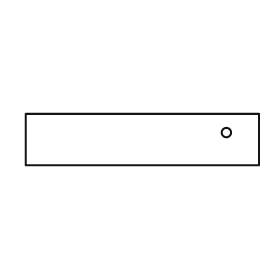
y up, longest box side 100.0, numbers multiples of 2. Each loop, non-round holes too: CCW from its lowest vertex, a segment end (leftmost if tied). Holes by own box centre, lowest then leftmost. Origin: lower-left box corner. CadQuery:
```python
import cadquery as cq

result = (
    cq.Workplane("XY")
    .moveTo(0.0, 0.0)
    .lineTo(100.0, 0.0)
    .lineTo(100.0, 22.0)
    .lineTo(0.0, 22.0)
    .close()
    .moveTo(86.0, 14.0)
    .circle(2.0)
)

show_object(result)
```